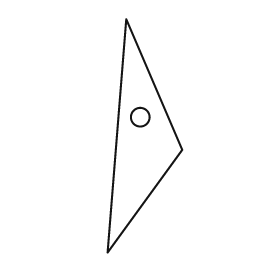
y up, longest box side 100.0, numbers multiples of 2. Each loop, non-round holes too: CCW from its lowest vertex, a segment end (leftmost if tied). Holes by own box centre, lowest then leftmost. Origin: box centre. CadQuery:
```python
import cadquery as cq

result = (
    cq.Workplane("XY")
    .moveTo(-16.0, -50.0)
    .lineTo(16.0, -6.0)
    .lineTo(-8.0, 50.0)
    .close()
    .moveTo(-2.0, 8.0)
    .circle(4.0)
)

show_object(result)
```